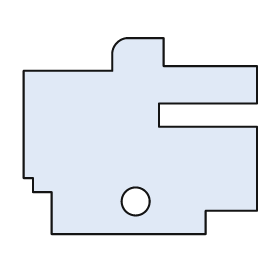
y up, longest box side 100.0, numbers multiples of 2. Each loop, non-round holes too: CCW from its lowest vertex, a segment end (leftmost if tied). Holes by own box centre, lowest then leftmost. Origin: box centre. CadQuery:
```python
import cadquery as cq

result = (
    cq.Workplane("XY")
    .moveTo(-38.0, -42.0)
    .lineTo(28.0, -42.0)
    .lineTo(28.0, -32.0)
    .lineTo(50.0, -32.0)
    .lineTo(50.0, 4.0)
    .lineTo(8.0, 4.0)
    .lineTo(8.0, 14.0)
    .lineTo(50.0, 14.0)
    .lineTo(50.0, 30.0)
    .lineTo(10.0, 30.0)
    .lineTo(10.0, 42.0)
    .lineTo(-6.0, 42.0)
    .threePointArc((-10.0, 40.0), (-12.0, 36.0))
    .lineTo(-12.0, 28.0)
    .lineTo(-50.0, 28.0)
    .lineTo(-50.0, -18.0)
    .lineTo(-46.0, -18.0)
    .lineTo(-46.0, -24.0)
    .lineTo(-38.0, -24.0)
    .close()
    .moveTo(-2.0, -28.0)
    .circle(6.0)
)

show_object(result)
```